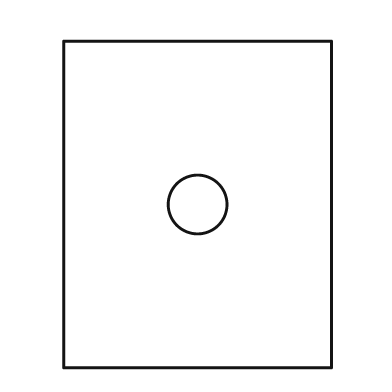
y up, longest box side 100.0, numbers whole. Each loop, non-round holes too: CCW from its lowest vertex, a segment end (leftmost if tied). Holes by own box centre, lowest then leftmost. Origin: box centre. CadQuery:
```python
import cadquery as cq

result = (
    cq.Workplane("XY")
    .moveTo(-41.0, -50.0)
    .lineTo(41.0, -50.0)
    .lineTo(41.0, 50.0)
    .lineTo(-41.0, 50.0)
    .close()
    .moveTo(0.0, 0.0)
    .circle(9.0)
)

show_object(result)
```